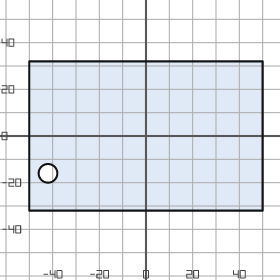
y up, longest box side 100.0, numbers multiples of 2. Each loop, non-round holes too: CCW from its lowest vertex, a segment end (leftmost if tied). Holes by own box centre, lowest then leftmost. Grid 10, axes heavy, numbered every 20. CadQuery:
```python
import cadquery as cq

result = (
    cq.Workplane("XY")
    .moveTo(-50.0, -32.0)
    .lineTo(50.0, -32.0)
    .lineTo(50.0, 32.0)
    .lineTo(-50.0, 32.0)
    .close()
    .moveTo(-42.0, -16.0)
    .circle(4.0)
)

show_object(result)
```